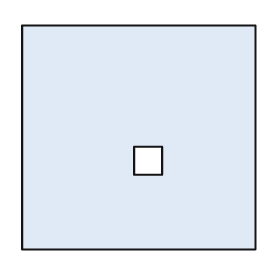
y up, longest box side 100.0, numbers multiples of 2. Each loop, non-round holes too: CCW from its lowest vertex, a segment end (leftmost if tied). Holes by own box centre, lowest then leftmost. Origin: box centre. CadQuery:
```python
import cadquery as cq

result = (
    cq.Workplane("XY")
    .moveTo(-50.0, -48.0)
    .lineTo(50.0, -48.0)
    .lineTo(50.0, 48.0)
    .lineTo(-50.0, 48.0)
    .close()
    .moveTo(-2.0, -16.0)
    .lineTo(10.0, -16.0)
    .lineTo(10.0, -4.0)
    .lineTo(-2.0, -4.0)
    .close()
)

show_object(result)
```